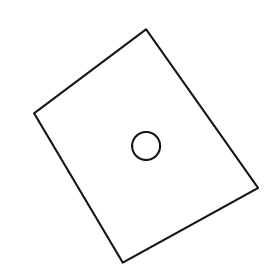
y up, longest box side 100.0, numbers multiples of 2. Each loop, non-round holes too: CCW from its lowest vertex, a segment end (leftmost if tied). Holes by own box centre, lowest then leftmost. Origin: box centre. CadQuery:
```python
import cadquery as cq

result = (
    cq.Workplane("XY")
    .moveTo(-10.0, -50.0)
    .lineTo(48.0, -18.0)
    .lineTo(0.0, 50.0)
    .lineTo(-48.0, 14.0)
    .close()
    .moveTo(0.0, 0.0)
    .circle(6.0)
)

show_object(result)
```